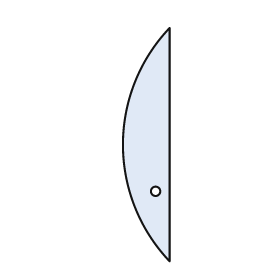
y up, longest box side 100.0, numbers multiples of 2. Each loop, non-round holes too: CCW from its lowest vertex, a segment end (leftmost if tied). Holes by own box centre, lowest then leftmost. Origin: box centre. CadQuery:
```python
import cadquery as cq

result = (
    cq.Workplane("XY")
    .moveTo(10.0, -50.0)
    .lineTo(10.0, 50.0)
    .threePointArc((-10.0, 0.0), (10.0, -50.0))
    .close()
    .moveTo(4.0, -20.0)
    .circle(2.0)
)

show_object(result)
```